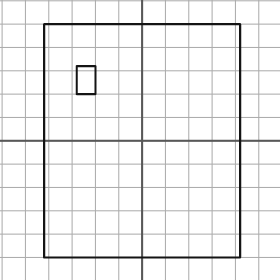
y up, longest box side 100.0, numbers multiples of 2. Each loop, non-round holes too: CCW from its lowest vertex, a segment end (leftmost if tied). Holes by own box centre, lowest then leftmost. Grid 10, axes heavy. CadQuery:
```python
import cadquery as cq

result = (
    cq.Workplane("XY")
    .moveTo(-42.0, -50.0)
    .lineTo(42.0, -50.0)
    .lineTo(42.0, 50.0)
    .lineTo(-42.0, 50.0)
    .close()
    .moveTo(-28.0, 20.0)
    .lineTo(-20.0, 20.0)
    .lineTo(-20.0, 32.0)
    .lineTo(-28.0, 32.0)
    .close()
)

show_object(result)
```